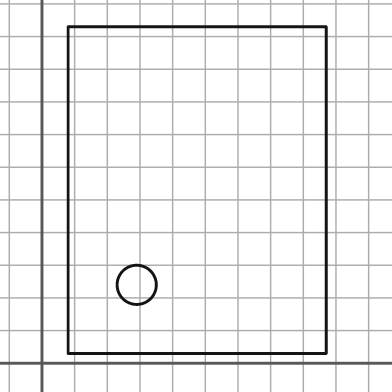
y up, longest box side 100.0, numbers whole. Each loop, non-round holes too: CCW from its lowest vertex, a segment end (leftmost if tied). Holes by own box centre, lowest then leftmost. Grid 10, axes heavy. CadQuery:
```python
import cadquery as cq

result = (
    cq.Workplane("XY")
    .moveTo(8.0, 3.0)
    .lineTo(87.0, 3.0)
    .lineTo(87.0, 103.0)
    .lineTo(8.0, 103.0)
    .close()
    .moveTo(29.0, 24.0)
    .circle(6.0)
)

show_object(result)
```